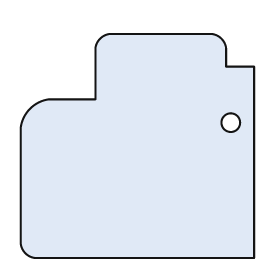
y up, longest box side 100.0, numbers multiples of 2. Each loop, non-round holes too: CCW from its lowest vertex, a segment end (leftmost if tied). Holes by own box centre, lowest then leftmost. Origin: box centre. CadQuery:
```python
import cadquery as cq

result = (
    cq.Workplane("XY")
    .moveTo(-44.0, -48.0)
    .lineTo(50.0, -48.0)
    .lineTo(50.0, 34.0)
    .lineTo(38.0, 34.0)
    .lineTo(38.0, 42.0)
    .threePointArc((36.0, 46.0), (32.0, 48.0))
    .lineTo(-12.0, 48.0)
    .threePointArc((-16.0, 46.0), (-18.0, 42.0))
    .lineTo(-18.0, 20.0)
    .lineTo(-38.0, 20.0)
    .threePointArc((-46.0, 16.0), (-50.0, 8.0))
    .lineTo(-50.0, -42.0)
    .threePointArc((-48.0, -46.0), (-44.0, -48.0))
    .close()
    .moveTo(40.0, 10.0)
    .circle(4.0)
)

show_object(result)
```